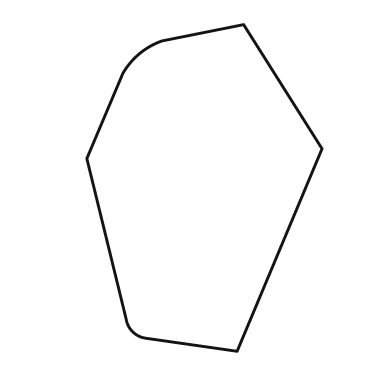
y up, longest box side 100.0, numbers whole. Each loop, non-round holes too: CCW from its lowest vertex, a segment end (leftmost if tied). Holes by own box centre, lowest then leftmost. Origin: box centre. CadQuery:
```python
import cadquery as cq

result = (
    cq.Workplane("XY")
    .moveTo(10.0, -50.0)
    .lineTo(36.0, 12.0)
    .lineTo(12.0, 50.0)
    .lineTo(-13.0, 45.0)
    .threePointArc((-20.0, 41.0), (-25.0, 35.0))
    .lineTo(-36.0, 9.0)
    .lineTo(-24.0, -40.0)
    .threePointArc((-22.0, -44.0), (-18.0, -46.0))
    .close()
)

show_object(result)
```